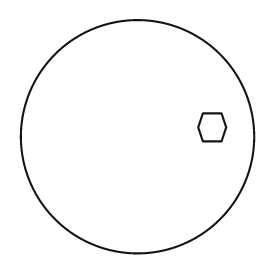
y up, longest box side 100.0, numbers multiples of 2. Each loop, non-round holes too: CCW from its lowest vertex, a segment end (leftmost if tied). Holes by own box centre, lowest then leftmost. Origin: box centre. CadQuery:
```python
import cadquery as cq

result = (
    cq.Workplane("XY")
    .moveTo(0.0, 0.0)
    .circle(50.0)
    .moveTo(28.0, -2.0)
    .lineTo(36.0, -2.0)
    .lineTo(38.0, 4.0)
    .lineTo(36.0, 10.0)
    .lineTo(28.0, 10.0)
    .lineTo(26.0, 4.0)
    .close()
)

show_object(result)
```